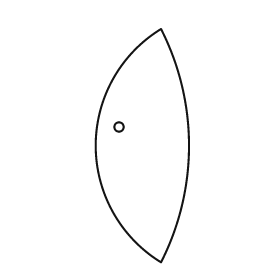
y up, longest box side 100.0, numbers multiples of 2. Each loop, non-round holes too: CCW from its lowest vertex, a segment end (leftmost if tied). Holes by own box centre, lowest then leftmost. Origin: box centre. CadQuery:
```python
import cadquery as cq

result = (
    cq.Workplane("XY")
    .moveTo(8.0, -50.0)
    .threePointArc((20.0, 0.0), (8.0, 50.0))
    .threePointArc((-20.0, 0.0), (8.0, -50.0))
    .close()
    .moveTo(-10.0, 8.0)
    .circle(2.0)
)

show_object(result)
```